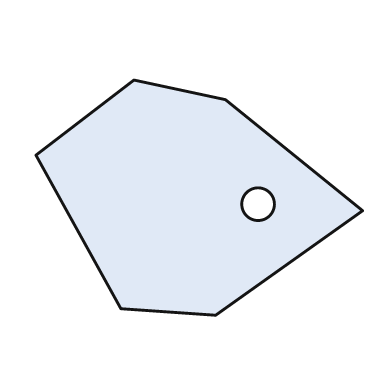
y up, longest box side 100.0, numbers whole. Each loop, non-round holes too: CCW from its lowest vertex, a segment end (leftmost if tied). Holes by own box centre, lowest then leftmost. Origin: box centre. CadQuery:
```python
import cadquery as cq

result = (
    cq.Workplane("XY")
    .moveTo(5.0, -36.0)
    .lineTo(50.0, -4.0)
    .lineTo(8.0, 30.0)
    .lineTo(-20.0, 36.0)
    .lineTo(-50.0, 13.0)
    .lineTo(-24.0, -34.0)
    .close()
    .moveTo(18.0, -2.0)
    .circle(5.0)
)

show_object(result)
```